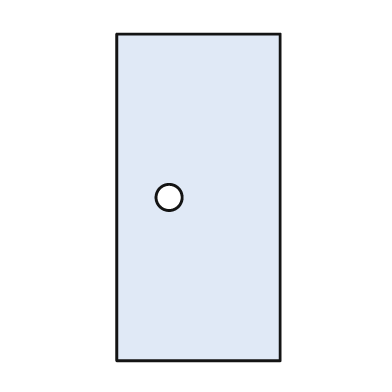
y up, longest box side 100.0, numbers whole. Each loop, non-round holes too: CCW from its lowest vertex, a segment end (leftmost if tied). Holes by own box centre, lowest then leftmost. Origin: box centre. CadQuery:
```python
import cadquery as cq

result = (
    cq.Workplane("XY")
    .moveTo(-25.0, -50.0)
    .lineTo(25.0, -50.0)
    .lineTo(25.0, 50.0)
    .lineTo(-25.0, 50.0)
    .close()
    .moveTo(-9.0, 0.0)
    .circle(4.0)
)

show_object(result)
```